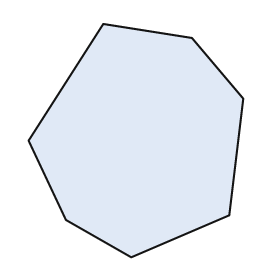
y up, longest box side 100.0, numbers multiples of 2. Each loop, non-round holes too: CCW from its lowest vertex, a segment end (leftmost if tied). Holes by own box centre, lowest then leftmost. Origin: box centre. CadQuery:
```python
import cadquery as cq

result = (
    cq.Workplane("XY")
    .moveTo(-2.0, -50.0)
    .lineTo(40.0, -32.0)
    .lineTo(46.0, 18.0)
    .lineTo(24.0, 44.0)
    .lineTo(-14.0, 50.0)
    .lineTo(-46.0, 0.0)
    .lineTo(-30.0, -34.0)
    .close()
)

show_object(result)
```